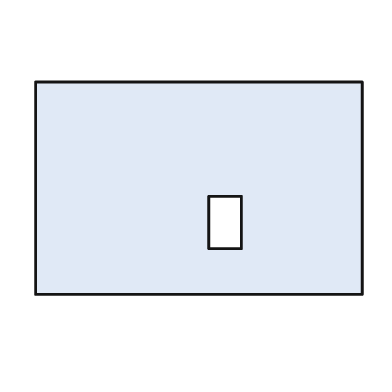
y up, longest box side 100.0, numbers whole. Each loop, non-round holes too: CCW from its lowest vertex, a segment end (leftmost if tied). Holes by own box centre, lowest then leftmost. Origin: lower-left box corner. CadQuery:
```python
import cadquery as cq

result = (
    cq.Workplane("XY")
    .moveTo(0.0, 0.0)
    .lineTo(100.0, 0.0)
    .lineTo(100.0, 65.0)
    .lineTo(0.0, 65.0)
    .close()
    .moveTo(53.0, 14.0)
    .lineTo(63.0, 14.0)
    .lineTo(63.0, 30.0)
    .lineTo(53.0, 30.0)
    .close()
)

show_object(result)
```